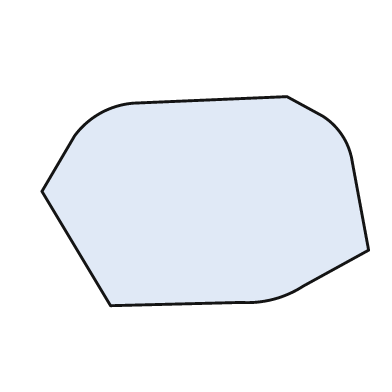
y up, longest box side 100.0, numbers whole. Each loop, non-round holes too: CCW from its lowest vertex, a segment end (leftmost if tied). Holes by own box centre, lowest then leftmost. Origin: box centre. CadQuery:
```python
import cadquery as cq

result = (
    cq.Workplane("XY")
    .moveTo(-29.0, -32.0)
    .lineTo(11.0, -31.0)
    .threePointArc((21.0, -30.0), (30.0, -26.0))
    .lineTo(50.0, -15.0)
    .lineTo(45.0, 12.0)
    .threePointArc((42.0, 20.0), (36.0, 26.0))
    .lineTo(25.0, 32.0)
    .lineTo(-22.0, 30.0)
    .threePointArc((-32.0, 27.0), (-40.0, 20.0))
    .lineTo(-50.0, 3.0)
    .close()
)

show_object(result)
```